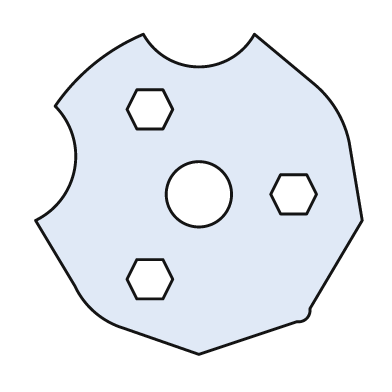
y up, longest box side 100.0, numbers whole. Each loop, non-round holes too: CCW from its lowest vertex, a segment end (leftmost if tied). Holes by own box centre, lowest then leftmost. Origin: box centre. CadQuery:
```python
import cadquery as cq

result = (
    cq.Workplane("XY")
    .moveTo(0.0, -49.0)
    .lineTo(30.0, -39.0)
    .threePointArc((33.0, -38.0), (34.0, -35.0))
    .lineTo(50.0, -8.0)
    .lineTo(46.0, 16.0)
    .threePointArc((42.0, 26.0), (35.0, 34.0))
    .lineTo(17.0, 49.0)
    .threePointArc((0.0, 39.0), (-17.0, 49.0))
    .threePointArc((-32.0, 40.0), (-44.0, 27.0))
    .threePointArc((-38.0, 8.0), (-50.0, -8.0))
    .lineTo(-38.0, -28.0)
    .threePointArc((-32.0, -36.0), (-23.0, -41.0))
    .close()
    .moveTo(-19.0, -32.0)
    .lineTo(-11.0, -32.0)
    .lineTo(-8.0, -26.0)
    .lineTo(-11.0, -20.0)
    .lineTo(-19.0, -20.0)
    .lineTo(-22.0, -26.0)
    .close()
    .moveTo(0.0, 0.0)
    .circle(10.0)
    .moveTo(25.0, -6.0)
    .lineTo(33.0, -6.0)
    .lineTo(36.0, 0.0)
    .lineTo(33.0, 6.0)
    .lineTo(25.0, 6.0)
    .lineTo(22.0, 0.0)
    .close()
    .moveTo(-19.0, 20.0)
    .lineTo(-11.0, 20.0)
    .lineTo(-8.0, 26.0)
    .lineTo(-11.0, 32.0)
    .lineTo(-19.0, 32.0)
    .lineTo(-22.0, 26.0)
    .close()
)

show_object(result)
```